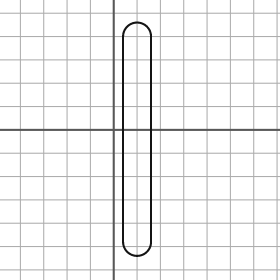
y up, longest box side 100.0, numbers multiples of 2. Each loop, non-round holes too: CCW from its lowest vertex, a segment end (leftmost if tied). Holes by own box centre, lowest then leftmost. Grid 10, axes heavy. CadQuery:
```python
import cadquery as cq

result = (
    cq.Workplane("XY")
    .moveTo(4.0, -48.0)
    .threePointArc((10.0, -54.0), (16.0, -48.0))
    .lineTo(16.0, 40.0)
    .threePointArc((10.0, 46.0), (4.0, 40.0))
    .close()
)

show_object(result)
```